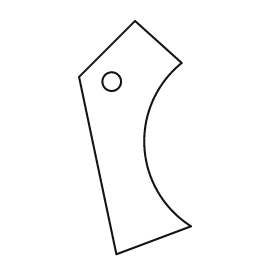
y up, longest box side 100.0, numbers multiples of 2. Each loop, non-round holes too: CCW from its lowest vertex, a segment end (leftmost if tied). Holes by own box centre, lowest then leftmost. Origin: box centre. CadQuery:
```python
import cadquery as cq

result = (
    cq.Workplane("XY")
    .moveTo(-8.0, -50.0)
    .lineTo(24.0, -38.0)
    .threePointArc((4.0, -4.0), (20.0, 32.0))
    .lineTo(0.0, 50.0)
    .lineTo(-24.0, 26.0)
    .close()
    .moveTo(-10.0, 24.0)
    .circle(4.0)
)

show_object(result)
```